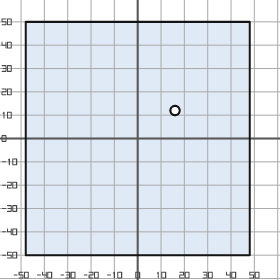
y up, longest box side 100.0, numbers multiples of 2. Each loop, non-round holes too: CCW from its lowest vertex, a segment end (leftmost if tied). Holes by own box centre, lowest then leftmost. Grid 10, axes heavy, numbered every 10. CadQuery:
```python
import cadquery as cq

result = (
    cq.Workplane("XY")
    .moveTo(-48.0, -50.0)
    .lineTo(48.0, -50.0)
    .lineTo(48.0, 50.0)
    .lineTo(-48.0, 50.0)
    .close()
    .moveTo(16.0, 12.0)
    .circle(2.0)
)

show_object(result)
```